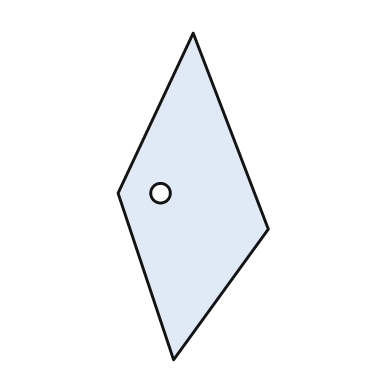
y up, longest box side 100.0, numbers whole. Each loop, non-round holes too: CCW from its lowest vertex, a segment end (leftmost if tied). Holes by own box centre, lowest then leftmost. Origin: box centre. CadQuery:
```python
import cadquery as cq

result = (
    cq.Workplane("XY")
    .moveTo(-6.0, -50.0)
    .lineTo(23.0, -10.0)
    .lineTo(0.0, 50.0)
    .lineTo(-23.0, 1.0)
    .close()
    .moveTo(-10.0, 1.0)
    .circle(3.0)
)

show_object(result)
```